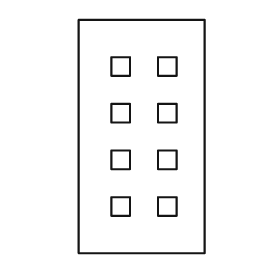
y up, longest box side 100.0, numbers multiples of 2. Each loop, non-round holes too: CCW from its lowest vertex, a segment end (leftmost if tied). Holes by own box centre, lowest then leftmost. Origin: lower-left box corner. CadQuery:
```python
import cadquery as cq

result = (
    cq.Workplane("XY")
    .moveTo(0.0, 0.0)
    .lineTo(54.0, 0.0)
    .lineTo(54.0, 100.0)
    .lineTo(0.0, 100.0)
    .close()
    .moveTo(14.0, 16.0)
    .lineTo(22.0, 16.0)
    .lineTo(22.0, 24.0)
    .lineTo(14.0, 24.0)
    .close()
    .moveTo(34.0, 16.0)
    .lineTo(42.0, 16.0)
    .lineTo(42.0, 24.0)
    .lineTo(34.0, 24.0)
    .close()
    .moveTo(14.0, 36.0)
    .lineTo(22.0, 36.0)
    .lineTo(22.0, 44.0)
    .lineTo(14.0, 44.0)
    .close()
    .moveTo(34.0, 36.0)
    .lineTo(42.0, 36.0)
    .lineTo(42.0, 44.0)
    .lineTo(34.0, 44.0)
    .close()
    .moveTo(14.0, 56.0)
    .lineTo(22.0, 56.0)
    .lineTo(22.0, 64.0)
    .lineTo(14.0, 64.0)
    .close()
    .moveTo(34.0, 56.0)
    .lineTo(42.0, 56.0)
    .lineTo(42.0, 64.0)
    .lineTo(34.0, 64.0)
    .close()
    .moveTo(14.0, 76.0)
    .lineTo(22.0, 76.0)
    .lineTo(22.0, 84.0)
    .lineTo(14.0, 84.0)
    .close()
    .moveTo(34.0, 76.0)
    .lineTo(42.0, 76.0)
    .lineTo(42.0, 84.0)
    .lineTo(34.0, 84.0)
    .close()
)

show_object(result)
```